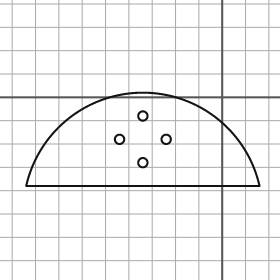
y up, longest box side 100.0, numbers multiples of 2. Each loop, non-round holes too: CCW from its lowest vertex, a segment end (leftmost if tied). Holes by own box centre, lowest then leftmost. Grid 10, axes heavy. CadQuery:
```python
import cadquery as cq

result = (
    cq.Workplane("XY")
    .moveTo(-84.0, -38.0)
    .lineTo(16.0, -38.0)
    .threePointArc((-34.0, 2.0), (-84.0, -38.0))
    .close()
    .moveTo(-34.0, -28.0)
    .circle(2.0)
    .moveTo(-44.0, -18.0)
    .circle(2.0)
    .moveTo(-24.0, -18.0)
    .circle(2.0)
    .moveTo(-34.0, -8.0)
    .circle(2.0)
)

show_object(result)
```